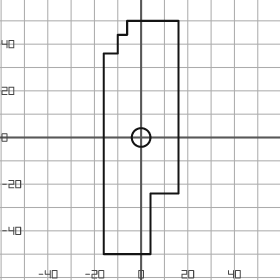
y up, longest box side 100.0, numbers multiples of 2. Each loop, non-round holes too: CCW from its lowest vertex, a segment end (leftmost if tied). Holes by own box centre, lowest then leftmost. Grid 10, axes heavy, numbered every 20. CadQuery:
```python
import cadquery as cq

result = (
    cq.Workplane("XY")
    .moveTo(-16.0, -50.0)
    .lineTo(4.0, -50.0)
    .lineTo(4.0, -24.0)
    .lineTo(16.0, -24.0)
    .lineTo(16.0, 50.0)
    .lineTo(-6.0, 50.0)
    .lineTo(-6.0, 44.0)
    .lineTo(-10.0, 44.0)
    .lineTo(-10.0, 36.0)
    .lineTo(-16.0, 36.0)
    .close()
    .moveTo(0.0, 0.0)
    .circle(4.0)
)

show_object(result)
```